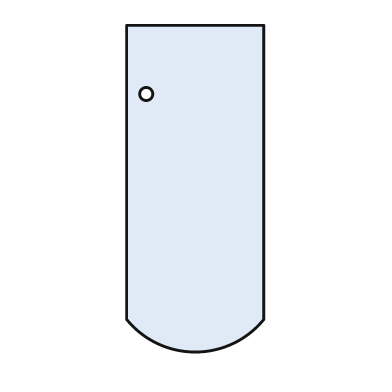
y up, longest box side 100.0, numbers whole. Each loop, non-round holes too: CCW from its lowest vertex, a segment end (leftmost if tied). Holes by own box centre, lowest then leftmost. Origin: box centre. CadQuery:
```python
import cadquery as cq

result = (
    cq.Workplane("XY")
    .moveTo(-21.0, -40.0)
    .threePointArc((0.0, -50.0), (21.0, -40.0))
    .lineTo(21.0, 50.0)
    .lineTo(-21.0, 50.0)
    .close()
    .moveTo(-15.0, 29.0)
    .circle(2.0)
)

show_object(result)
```